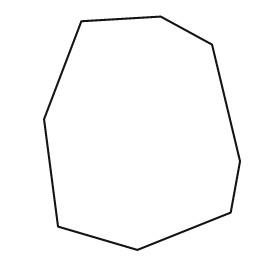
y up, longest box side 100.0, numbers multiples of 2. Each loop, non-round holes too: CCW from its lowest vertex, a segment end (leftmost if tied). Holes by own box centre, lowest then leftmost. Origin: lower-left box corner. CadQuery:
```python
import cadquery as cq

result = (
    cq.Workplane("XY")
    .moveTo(40.0, 0.0)
    .lineTo(80.0, 16.0)
    .lineTo(84.0, 38.0)
    .lineTo(72.0, 88.0)
    .lineTo(50.0, 100.0)
    .lineTo(16.0, 98.0)
    .lineTo(0.0, 56.0)
    .lineTo(6.0, 10.0)
    .close()
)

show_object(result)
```